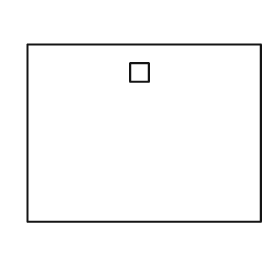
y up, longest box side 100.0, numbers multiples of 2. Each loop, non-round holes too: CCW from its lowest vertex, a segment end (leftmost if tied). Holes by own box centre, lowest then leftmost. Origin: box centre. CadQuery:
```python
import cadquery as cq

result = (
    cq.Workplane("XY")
    .moveTo(-50.0, -38.0)
    .lineTo(50.0, -38.0)
    .lineTo(50.0, 38.0)
    .lineTo(-50.0, 38.0)
    .close()
    .moveTo(-6.0, 22.0)
    .lineTo(2.0, 22.0)
    .lineTo(2.0, 30.0)
    .lineTo(-6.0, 30.0)
    .close()
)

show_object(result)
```